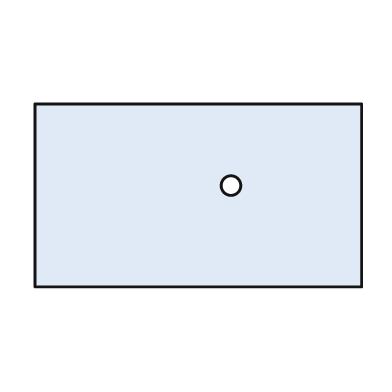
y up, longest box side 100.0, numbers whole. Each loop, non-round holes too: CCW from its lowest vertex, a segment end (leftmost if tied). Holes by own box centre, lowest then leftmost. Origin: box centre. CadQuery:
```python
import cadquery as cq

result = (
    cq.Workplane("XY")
    .moveTo(-50.0, -28.0)
    .lineTo(50.0, -28.0)
    .lineTo(50.0, 28.0)
    .lineTo(-50.0, 28.0)
    .close()
    .moveTo(10.0, 3.0)
    .circle(3.0)
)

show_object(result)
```